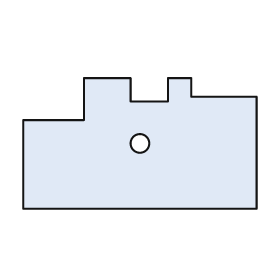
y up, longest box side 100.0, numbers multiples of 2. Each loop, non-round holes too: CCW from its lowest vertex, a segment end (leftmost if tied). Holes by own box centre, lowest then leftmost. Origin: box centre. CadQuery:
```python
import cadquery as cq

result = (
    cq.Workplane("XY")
    .moveTo(-50.0, -28.0)
    .lineTo(50.0, -28.0)
    .lineTo(50.0, 20.0)
    .lineTo(22.0, 20.0)
    .lineTo(22.0, 28.0)
    .lineTo(12.0, 28.0)
    .lineTo(12.0, 18.0)
    .lineTo(-4.0, 18.0)
    .lineTo(-4.0, 28.0)
    .lineTo(-24.0, 28.0)
    .lineTo(-24.0, 10.0)
    .lineTo(-50.0, 10.0)
    .close()
    .moveTo(0.0, 0.0)
    .circle(4.0)
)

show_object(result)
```